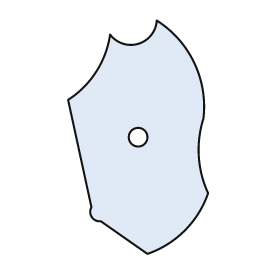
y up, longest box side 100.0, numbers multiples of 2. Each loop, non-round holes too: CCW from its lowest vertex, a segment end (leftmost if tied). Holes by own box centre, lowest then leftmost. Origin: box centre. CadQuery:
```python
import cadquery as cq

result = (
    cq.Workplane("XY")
    .moveTo(4.0, -50.0)
    .threePointArc((20.0, -40.0), (30.0, -24.0))
    .threePointArc((26.0, -8.0), (28.0, 8.0))
    .threePointArc((24.0, 32.0), (8.0, 50.0))
    .threePointArc((0.0, 40.0), (-12.0, 44.0))
    .threePointArc((-18.0, 28.0), (-30.0, 16.0))
    .lineTo(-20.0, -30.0)
    .threePointArc((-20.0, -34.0), (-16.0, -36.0))
    .close()
    .moveTo(0.0, 0.0)
    .circle(4.0)
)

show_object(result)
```